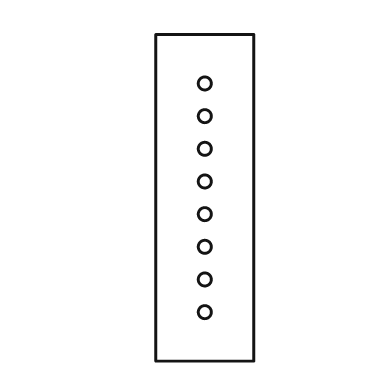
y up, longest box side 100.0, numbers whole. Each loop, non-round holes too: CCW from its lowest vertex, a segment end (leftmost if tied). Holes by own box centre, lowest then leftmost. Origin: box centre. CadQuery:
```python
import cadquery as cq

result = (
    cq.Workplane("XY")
    .moveTo(-15.0, -50.0)
    .lineTo(15.0, -50.0)
    .lineTo(15.0, 50.0)
    .lineTo(-15.0, 50.0)
    .close()
    .moveTo(0.0, -35.0)
    .circle(2.0)
    .moveTo(0.0, -25.0)
    .circle(2.0)
    .moveTo(0.0, -15.0)
    .circle(2.0)
    .moveTo(0.0, -5.0)
    .circle(2.0)
    .moveTo(0.0, 5.0)
    .circle(2.0)
    .moveTo(0.0, 15.0)
    .circle(2.0)
    .moveTo(0.0, 25.0)
    .circle(2.0)
    .moveTo(0.0, 35.0)
    .circle(2.0)
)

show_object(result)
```